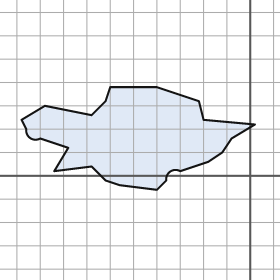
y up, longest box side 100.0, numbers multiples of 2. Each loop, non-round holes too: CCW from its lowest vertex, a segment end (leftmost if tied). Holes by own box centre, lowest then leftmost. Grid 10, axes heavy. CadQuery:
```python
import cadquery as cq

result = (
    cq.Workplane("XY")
    .moveTo(-40.0, -6.0)
    .lineTo(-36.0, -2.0)
    .threePointArc((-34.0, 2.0), (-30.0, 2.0))
    .lineTo(-18.0, 6.0)
    .lineTo(-12.0, 10.0)
    .lineTo(-8.0, 16.0)
    .lineTo(2.0, 22.0)
    .lineTo(-20.0, 24.0)
    .lineTo(-22.0, 32.0)
    .lineTo(-40.0, 38.0)
    .lineTo(-60.0, 38.0)
    .lineTo(-62.0, 32.0)
    .lineTo(-68.0, 26.0)
    .lineTo(-88.0, 30.0)
    .lineTo(-98.0, 24.0)
    .lineTo(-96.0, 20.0)
    .threePointArc((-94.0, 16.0), (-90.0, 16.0))
    .lineTo(-78.0, 12.0)
    .lineTo(-84.0, 2.0)
    .lineTo(-68.0, 4.0)
    .lineTo(-62.0, -2.0)
    .lineTo(-56.0, -4.0)
    .close()
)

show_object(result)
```